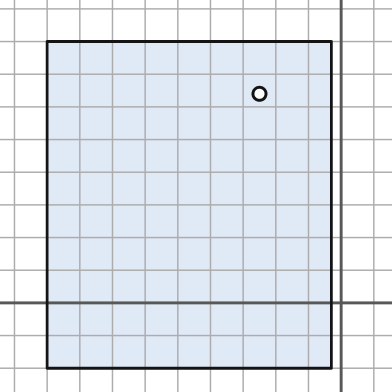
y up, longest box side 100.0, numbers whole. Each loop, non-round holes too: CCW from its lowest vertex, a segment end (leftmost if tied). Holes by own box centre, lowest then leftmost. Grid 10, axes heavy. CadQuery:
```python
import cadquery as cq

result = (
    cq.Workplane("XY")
    .moveTo(-90.0, -20.0)
    .lineTo(-3.0, -20.0)
    .lineTo(-3.0, 80.0)
    .lineTo(-90.0, 80.0)
    .close()
    .moveTo(-25.0, 64.0)
    .circle(2.0)
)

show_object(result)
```